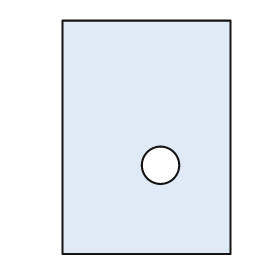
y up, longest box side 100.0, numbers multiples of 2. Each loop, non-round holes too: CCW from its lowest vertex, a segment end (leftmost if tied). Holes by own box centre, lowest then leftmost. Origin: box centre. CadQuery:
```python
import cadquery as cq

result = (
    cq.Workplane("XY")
    .moveTo(-36.0, -50.0)
    .lineTo(36.0, -50.0)
    .lineTo(36.0, 50.0)
    .lineTo(-36.0, 50.0)
    .close()
    .moveTo(6.0, -12.0)
    .circle(8.0)
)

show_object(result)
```